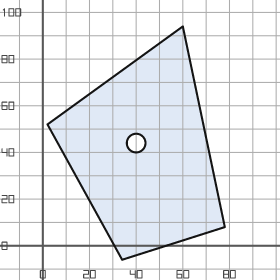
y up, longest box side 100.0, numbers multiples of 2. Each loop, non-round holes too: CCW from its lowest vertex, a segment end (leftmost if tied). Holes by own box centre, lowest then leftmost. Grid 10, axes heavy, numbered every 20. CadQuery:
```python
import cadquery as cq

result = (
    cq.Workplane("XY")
    .moveTo(34.0, -6.0)
    .lineTo(78.0, 8.0)
    .lineTo(60.0, 94.0)
    .lineTo(2.0, 52.0)
    .close()
    .moveTo(40.0, 44.0)
    .circle(4.0)
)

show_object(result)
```